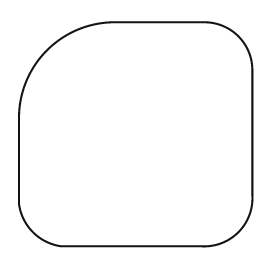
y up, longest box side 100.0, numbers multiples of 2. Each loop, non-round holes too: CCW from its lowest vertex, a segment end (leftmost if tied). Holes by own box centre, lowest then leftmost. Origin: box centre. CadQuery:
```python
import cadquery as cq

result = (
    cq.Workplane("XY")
    .moveTo(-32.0, -48.0)
    .lineTo(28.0, -48.0)
    .threePointArc((44.0, -42.0), (50.0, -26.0))
    .lineTo(50.0, 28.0)
    .threePointArc((44.0, 42.0), (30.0, 48.0))
    .lineTo(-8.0, 48.0)
    .threePointArc((-38.0, 36.0), (-50.0, 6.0))
    .lineTo(-50.0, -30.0)
    .threePointArc((-44.0, -42.0), (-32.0, -48.0))
    .close()
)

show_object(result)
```